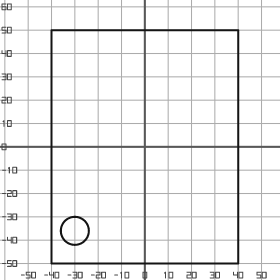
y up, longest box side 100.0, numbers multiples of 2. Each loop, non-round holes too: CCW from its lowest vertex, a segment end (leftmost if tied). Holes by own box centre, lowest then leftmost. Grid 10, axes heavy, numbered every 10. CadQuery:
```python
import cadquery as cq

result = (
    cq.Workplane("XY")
    .moveTo(-40.0, -50.0)
    .lineTo(40.0, -50.0)
    .lineTo(40.0, 50.0)
    .lineTo(-40.0, 50.0)
    .close()
    .moveTo(-30.0, -36.0)
    .circle(6.0)
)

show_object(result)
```